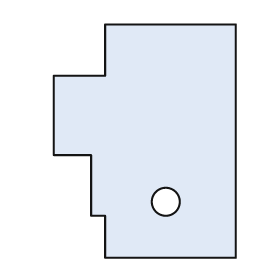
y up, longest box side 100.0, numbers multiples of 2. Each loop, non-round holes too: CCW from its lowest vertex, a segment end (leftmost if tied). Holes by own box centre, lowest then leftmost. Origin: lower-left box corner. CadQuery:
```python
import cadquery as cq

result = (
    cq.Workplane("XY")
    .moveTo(22.0, 0.0)
    .lineTo(78.0, 0.0)
    .lineTo(78.0, 100.0)
    .lineTo(22.0, 100.0)
    .lineTo(22.0, 78.0)
    .lineTo(0.0, 78.0)
    .lineTo(0.0, 44.0)
    .lineTo(16.0, 44.0)
    .lineTo(16.0, 18.0)
    .lineTo(22.0, 18.0)
    .close()
    .moveTo(48.0, 24.0)
    .circle(6.0)
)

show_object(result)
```